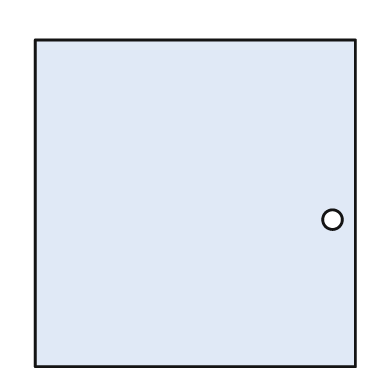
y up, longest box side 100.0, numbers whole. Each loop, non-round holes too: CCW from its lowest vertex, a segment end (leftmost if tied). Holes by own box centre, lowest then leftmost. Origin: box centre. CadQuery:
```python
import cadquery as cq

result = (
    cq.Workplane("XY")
    .moveTo(-49.0, -50.0)
    .lineTo(49.0, -50.0)
    .lineTo(49.0, 50.0)
    .lineTo(-49.0, 50.0)
    .close()
    .moveTo(42.0, -5.0)
    .circle(3.0)
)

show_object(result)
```